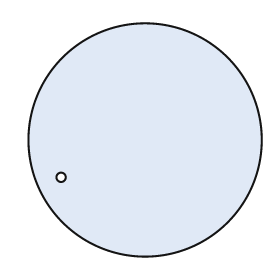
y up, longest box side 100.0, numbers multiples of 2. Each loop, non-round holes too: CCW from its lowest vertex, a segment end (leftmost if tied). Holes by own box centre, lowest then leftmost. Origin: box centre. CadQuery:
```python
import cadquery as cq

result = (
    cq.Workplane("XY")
    .moveTo(0.0, 0.0)
    .circle(50.0)
    .moveTo(-36.0, -16.0)
    .circle(2.0)
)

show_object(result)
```